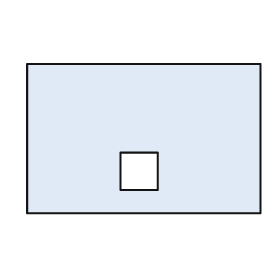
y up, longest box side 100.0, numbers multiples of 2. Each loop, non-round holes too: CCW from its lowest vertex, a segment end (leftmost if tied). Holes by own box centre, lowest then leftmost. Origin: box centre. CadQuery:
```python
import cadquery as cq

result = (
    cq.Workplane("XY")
    .moveTo(-50.0, -32.0)
    .lineTo(50.0, -32.0)
    .lineTo(50.0, 32.0)
    .lineTo(-50.0, 32.0)
    .close()
    .moveTo(-10.0, -22.0)
    .lineTo(6.0, -22.0)
    .lineTo(6.0, -6.0)
    .lineTo(-10.0, -6.0)
    .close()
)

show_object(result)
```